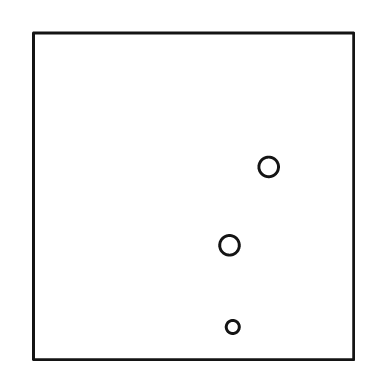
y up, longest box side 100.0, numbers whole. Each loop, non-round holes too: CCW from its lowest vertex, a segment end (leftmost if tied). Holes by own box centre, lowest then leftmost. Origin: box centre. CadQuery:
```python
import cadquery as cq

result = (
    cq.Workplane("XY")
    .moveTo(-49.0, -50.0)
    .lineTo(49.0, -50.0)
    .lineTo(49.0, 50.0)
    .lineTo(-49.0, 50.0)
    .close()
    .moveTo(12.0, -40.0)
    .circle(2.0)
    .moveTo(11.0, -15.0)
    .circle(3.0)
    .moveTo(23.0, 9.0)
    .circle(3.0)
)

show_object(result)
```